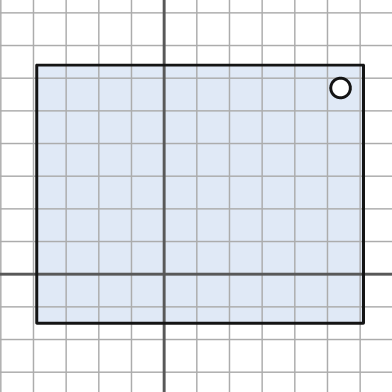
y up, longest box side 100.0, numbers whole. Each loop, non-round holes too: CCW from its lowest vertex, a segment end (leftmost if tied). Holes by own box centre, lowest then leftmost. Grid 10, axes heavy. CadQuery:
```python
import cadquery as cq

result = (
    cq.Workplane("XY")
    .moveTo(-39.0, -15.0)
    .lineTo(61.0, -15.0)
    .lineTo(61.0, 64.0)
    .lineTo(-39.0, 64.0)
    .close()
    .moveTo(54.0, 57.0)
    .circle(3.0)
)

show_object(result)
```